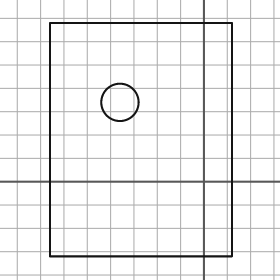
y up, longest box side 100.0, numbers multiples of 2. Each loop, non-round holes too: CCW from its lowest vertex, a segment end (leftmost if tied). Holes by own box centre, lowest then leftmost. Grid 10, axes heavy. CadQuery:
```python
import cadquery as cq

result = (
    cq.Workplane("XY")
    .moveTo(-66.0, -32.0)
    .lineTo(12.0, -32.0)
    .lineTo(12.0, 68.0)
    .lineTo(-66.0, 68.0)
    .close()
    .moveTo(-36.0, 34.0)
    .circle(8.0)
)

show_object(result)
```